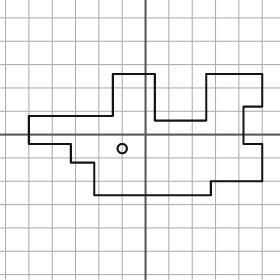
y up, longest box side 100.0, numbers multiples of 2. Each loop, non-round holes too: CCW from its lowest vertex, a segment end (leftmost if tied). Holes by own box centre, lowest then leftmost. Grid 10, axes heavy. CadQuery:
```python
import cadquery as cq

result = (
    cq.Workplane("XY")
    .moveTo(-22.0, -26.0)
    .lineTo(28.0, -26.0)
    .lineTo(28.0, -20.0)
    .lineTo(50.0, -20.0)
    .lineTo(50.0, -4.0)
    .lineTo(42.0, -4.0)
    .lineTo(42.0, 12.0)
    .lineTo(50.0, 12.0)
    .lineTo(50.0, 26.0)
    .lineTo(26.0, 26.0)
    .lineTo(26.0, 6.0)
    .lineTo(4.0, 6.0)
    .lineTo(4.0, 26.0)
    .lineTo(-14.0, 26.0)
    .lineTo(-14.0, 8.0)
    .lineTo(-50.0, 8.0)
    .lineTo(-50.0, -4.0)
    .lineTo(-32.0, -4.0)
    .lineTo(-32.0, -12.0)
    .lineTo(-22.0, -12.0)
    .close()
    .moveTo(-10.0, -6.0)
    .circle(2.0)
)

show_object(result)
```